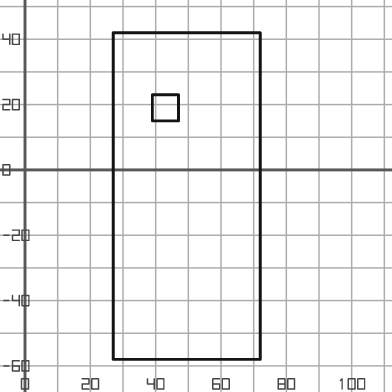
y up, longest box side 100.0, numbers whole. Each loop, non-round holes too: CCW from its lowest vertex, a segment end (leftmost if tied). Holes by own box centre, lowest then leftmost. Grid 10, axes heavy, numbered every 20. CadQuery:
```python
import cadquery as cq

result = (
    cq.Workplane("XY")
    .moveTo(27.0, -58.0)
    .lineTo(72.0, -58.0)
    .lineTo(72.0, 42.0)
    .lineTo(27.0, 42.0)
    .close()
    .moveTo(39.0, 15.0)
    .lineTo(47.0, 15.0)
    .lineTo(47.0, 23.0)
    .lineTo(39.0, 23.0)
    .close()
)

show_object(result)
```